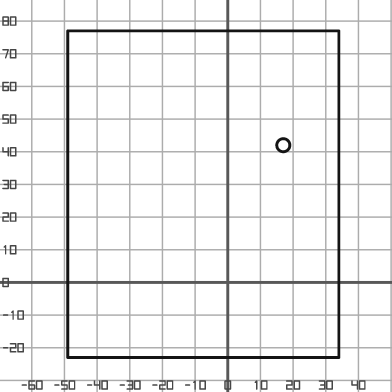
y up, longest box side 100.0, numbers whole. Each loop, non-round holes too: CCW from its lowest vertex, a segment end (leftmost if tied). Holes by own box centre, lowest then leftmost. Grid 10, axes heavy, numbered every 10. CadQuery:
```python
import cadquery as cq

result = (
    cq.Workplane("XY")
    .moveTo(-49.0, -23.0)
    .lineTo(34.0, -23.0)
    .lineTo(34.0, 77.0)
    .lineTo(-49.0, 77.0)
    .close()
    .moveTo(17.0, 42.0)
    .circle(2.0)
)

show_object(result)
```